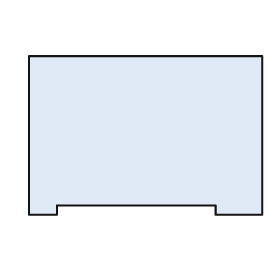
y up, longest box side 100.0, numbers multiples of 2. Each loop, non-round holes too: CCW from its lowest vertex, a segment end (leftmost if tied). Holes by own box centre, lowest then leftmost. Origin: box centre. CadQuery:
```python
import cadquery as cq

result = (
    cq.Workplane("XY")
    .moveTo(-50.0, -34.0)
    .lineTo(-38.0, -34.0)
    .lineTo(-38.0, -30.0)
    .lineTo(30.0, -30.0)
    .lineTo(30.0, -34.0)
    .lineTo(50.0, -34.0)
    .lineTo(50.0, 34.0)
    .lineTo(-50.0, 34.0)
    .close()
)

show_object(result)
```